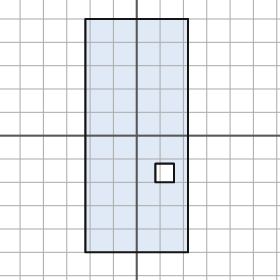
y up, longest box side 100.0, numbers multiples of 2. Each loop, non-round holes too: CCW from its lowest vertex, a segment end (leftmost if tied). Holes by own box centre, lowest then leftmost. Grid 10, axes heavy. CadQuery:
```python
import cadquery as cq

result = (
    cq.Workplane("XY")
    .moveTo(-22.0, -50.0)
    .lineTo(22.0, -50.0)
    .lineTo(22.0, 50.0)
    .lineTo(-22.0, 50.0)
    .close()
    .moveTo(8.0, -20.0)
    .lineTo(16.0, -20.0)
    .lineTo(16.0, -12.0)
    .lineTo(8.0, -12.0)
    .close()
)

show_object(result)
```